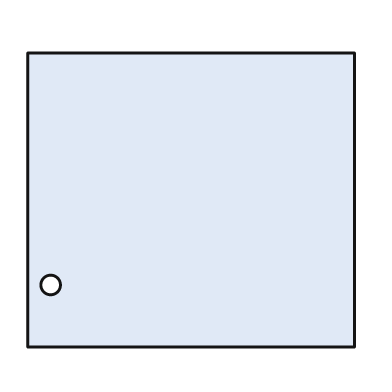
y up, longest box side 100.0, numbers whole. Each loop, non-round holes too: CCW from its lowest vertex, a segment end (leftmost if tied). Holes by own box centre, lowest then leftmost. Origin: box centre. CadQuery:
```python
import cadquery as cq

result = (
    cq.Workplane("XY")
    .moveTo(-50.0, -45.0)
    .lineTo(50.0, -45.0)
    .lineTo(50.0, 45.0)
    .lineTo(-50.0, 45.0)
    .close()
    .moveTo(-43.0, -26.0)
    .circle(3.0)
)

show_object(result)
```